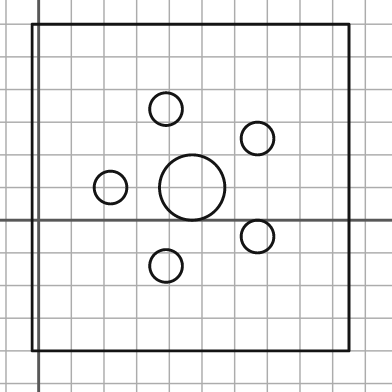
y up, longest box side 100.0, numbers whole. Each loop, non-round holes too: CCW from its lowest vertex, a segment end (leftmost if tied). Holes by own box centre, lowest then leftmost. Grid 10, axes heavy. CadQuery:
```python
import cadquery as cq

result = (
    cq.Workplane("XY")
    .moveTo(-2.0, -40.0)
    .lineTo(95.0, -40.0)
    .lineTo(95.0, 60.0)
    .lineTo(-2.0, 60.0)
    .close()
    .moveTo(39.0, -14.0)
    .circle(5.0)
    .moveTo(67.0, -5.0)
    .circle(5.0)
    .moveTo(22.0, 10.0)
    .circle(5.0)
    .moveTo(47.0, 10.0)
    .circle(10.0)
    .moveTo(67.0, 25.0)
    .circle(5.0)
    .moveTo(39.0, 34.0)
    .circle(5.0)
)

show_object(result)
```